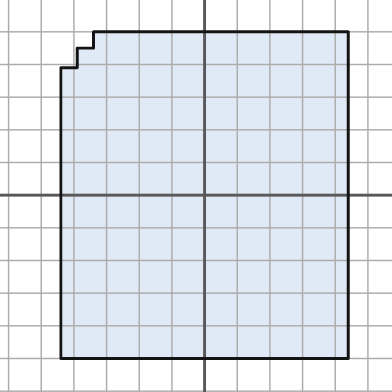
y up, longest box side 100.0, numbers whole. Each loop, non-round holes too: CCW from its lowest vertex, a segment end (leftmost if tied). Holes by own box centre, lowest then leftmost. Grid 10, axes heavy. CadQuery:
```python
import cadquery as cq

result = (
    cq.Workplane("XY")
    .moveTo(-44.0, -50.0)
    .lineTo(44.0, -50.0)
    .lineTo(44.0, 50.0)
    .lineTo(-34.0, 50.0)
    .lineTo(-34.0, 45.0)
    .lineTo(-39.0, 45.0)
    .lineTo(-39.0, 39.0)
    .lineTo(-44.0, 39.0)
    .close()
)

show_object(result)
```